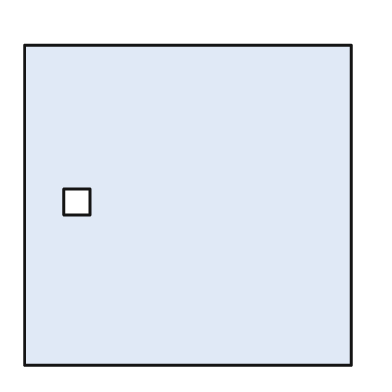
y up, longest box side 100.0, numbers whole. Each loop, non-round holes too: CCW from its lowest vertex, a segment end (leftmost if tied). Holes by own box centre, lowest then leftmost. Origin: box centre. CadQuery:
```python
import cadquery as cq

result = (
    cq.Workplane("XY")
    .moveTo(-50.0, -49.0)
    .lineTo(50.0, -49.0)
    .lineTo(50.0, 49.0)
    .lineTo(-50.0, 49.0)
    .close()
    .moveTo(-38.0, -3.0)
    .lineTo(-30.0, -3.0)
    .lineTo(-30.0, 5.0)
    .lineTo(-38.0, 5.0)
    .close()
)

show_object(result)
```